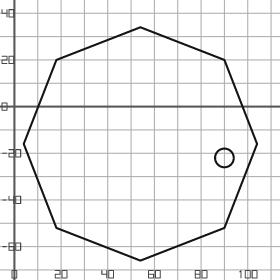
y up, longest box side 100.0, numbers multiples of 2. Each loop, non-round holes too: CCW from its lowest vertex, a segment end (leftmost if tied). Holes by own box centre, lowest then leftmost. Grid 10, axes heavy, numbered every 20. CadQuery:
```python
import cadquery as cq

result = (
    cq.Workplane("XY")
    .moveTo(54.0, -66.0)
    .lineTo(90.0, -52.0)
    .lineTo(104.0, -16.0)
    .lineTo(90.0, 20.0)
    .lineTo(54.0, 34.0)
    .lineTo(18.0, 20.0)
    .lineTo(4.0, -16.0)
    .lineTo(18.0, -52.0)
    .close()
    .moveTo(90.0, -22.0)
    .circle(4.0)
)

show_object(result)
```